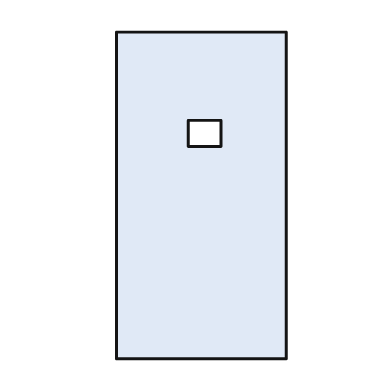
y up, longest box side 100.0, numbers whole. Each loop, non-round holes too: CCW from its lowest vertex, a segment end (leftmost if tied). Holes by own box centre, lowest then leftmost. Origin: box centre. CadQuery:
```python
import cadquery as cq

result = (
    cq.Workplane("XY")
    .moveTo(-26.0, -50.0)
    .lineTo(26.0, -50.0)
    .lineTo(26.0, 50.0)
    .lineTo(-26.0, 50.0)
    .close()
    .moveTo(-4.0, 15.0)
    .lineTo(6.0, 15.0)
    .lineTo(6.0, 23.0)
    .lineTo(-4.0, 23.0)
    .close()
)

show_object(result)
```